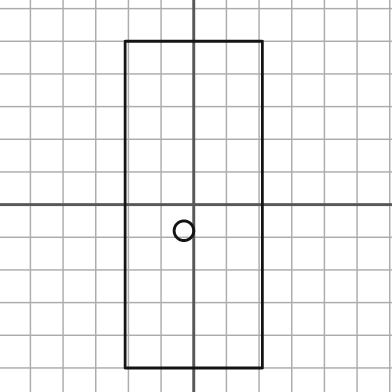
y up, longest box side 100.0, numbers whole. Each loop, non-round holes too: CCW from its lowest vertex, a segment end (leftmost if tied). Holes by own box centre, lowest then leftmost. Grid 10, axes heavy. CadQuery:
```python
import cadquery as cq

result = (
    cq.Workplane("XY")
    .moveTo(-21.0, -50.0)
    .lineTo(21.0, -50.0)
    .lineTo(21.0, 50.0)
    .lineTo(-21.0, 50.0)
    .close()
    .moveTo(-3.0, -8.0)
    .circle(3.0)
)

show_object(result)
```